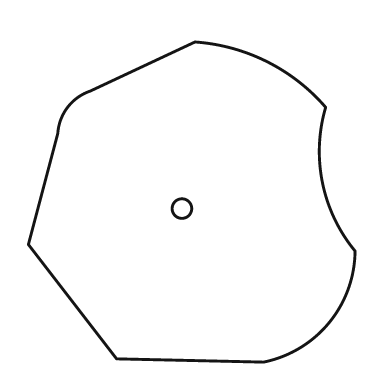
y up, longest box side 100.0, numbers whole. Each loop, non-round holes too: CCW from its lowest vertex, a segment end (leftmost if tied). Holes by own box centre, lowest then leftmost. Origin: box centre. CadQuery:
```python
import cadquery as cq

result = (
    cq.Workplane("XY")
    .moveTo(22.0, -49.0)
    .threePointArc((42.0, -37.0), (50.0, -15.0))
    .threePointArc((40.0, 6.0), (41.0, 29.0))
    .threePointArc((23.0, 43.0), (1.0, 49.0))
    .lineTo(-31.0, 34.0)
    .threePointArc((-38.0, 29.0), (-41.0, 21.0))
    .lineTo(-50.0, -13.0)
    .lineTo(-23.0, -48.0)
    .close()
    .moveTo(-3.0, -2.0)
    .circle(3.0)
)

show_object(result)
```